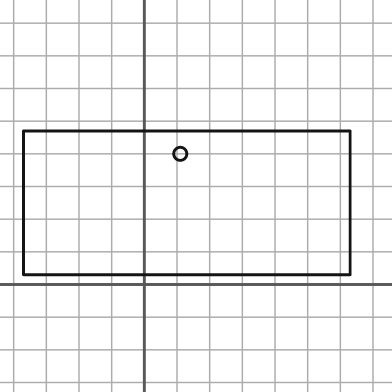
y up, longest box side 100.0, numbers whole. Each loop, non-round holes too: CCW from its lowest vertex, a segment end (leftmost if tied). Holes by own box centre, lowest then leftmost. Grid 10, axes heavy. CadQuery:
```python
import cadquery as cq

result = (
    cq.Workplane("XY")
    .moveTo(-37.0, 3.0)
    .lineTo(63.0, 3.0)
    .lineTo(63.0, 47.0)
    .lineTo(-37.0, 47.0)
    .close()
    .moveTo(11.0, 40.0)
    .circle(2.0)
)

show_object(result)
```